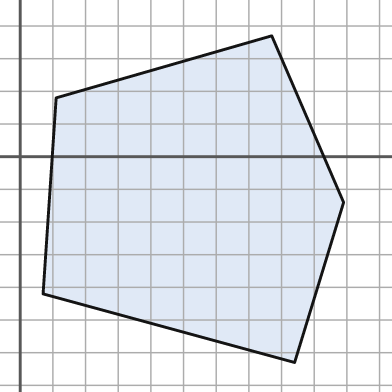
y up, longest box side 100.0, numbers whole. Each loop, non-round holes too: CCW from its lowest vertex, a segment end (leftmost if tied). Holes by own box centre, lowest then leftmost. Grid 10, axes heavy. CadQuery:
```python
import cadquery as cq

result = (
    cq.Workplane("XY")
    .moveTo(84.0, -63.0)
    .lineTo(99.0, -14.0)
    .lineTo(77.0, 37.0)
    .lineTo(11.0, 18.0)
    .lineTo(7.0, -42.0)
    .close()
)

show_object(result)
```